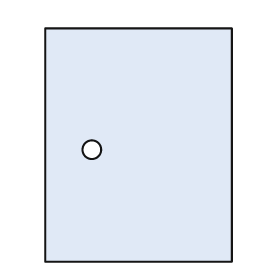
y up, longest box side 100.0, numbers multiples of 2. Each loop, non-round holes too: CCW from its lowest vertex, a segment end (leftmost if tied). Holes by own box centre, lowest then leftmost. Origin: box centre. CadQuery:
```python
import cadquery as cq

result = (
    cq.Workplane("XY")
    .moveTo(-40.0, -50.0)
    .lineTo(40.0, -50.0)
    .lineTo(40.0, 50.0)
    .lineTo(-40.0, 50.0)
    .close()
    .moveTo(-20.0, -2.0)
    .circle(4.0)
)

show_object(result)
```